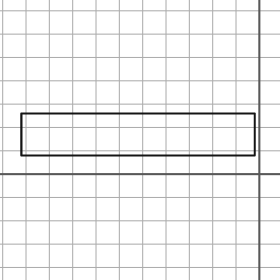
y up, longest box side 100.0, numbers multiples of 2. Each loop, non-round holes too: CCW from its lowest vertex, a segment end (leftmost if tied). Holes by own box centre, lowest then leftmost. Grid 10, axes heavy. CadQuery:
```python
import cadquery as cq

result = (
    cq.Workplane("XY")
    .moveTo(-102.0, 8.0)
    .lineTo(-2.0, 8.0)
    .lineTo(-2.0, 26.0)
    .lineTo(-102.0, 26.0)
    .close()
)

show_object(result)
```